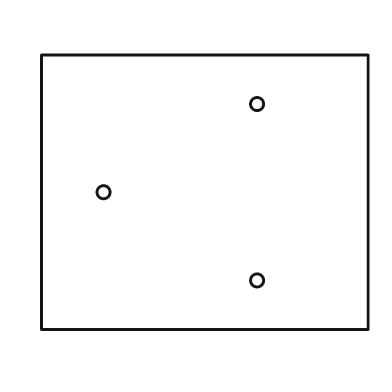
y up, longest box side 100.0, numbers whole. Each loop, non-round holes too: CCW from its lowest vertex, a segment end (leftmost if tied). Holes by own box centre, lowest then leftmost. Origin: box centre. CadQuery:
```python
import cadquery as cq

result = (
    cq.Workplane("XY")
    .moveTo(-50.0, -42.0)
    .lineTo(50.0, -42.0)
    .lineTo(50.0, 42.0)
    .lineTo(-50.0, 42.0)
    .close()
    .moveTo(16.0, -27.0)
    .circle(2.0)
    .moveTo(-31.0, 0.0)
    .circle(2.0)
    .moveTo(16.0, 27.0)
    .circle(2.0)
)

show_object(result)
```